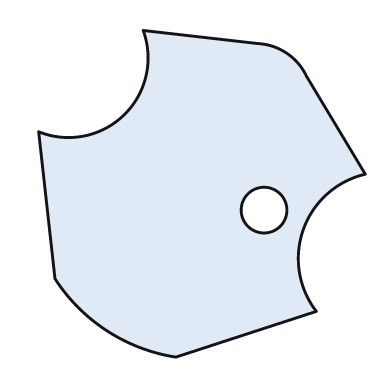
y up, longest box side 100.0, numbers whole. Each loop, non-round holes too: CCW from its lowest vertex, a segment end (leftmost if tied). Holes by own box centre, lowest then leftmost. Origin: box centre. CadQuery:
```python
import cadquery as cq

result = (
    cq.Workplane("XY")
    .moveTo(-8.0, -50.0)
    .lineTo(35.0, -36.0)
    .threePointArc((31.0, -11.0), (50.0, 6.0))
    .lineTo(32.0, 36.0)
    .threePointArc((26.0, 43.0), (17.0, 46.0))
    .lineTo(-18.0, 50.0)
    .threePointArc((-24.0, 24.0), (-50.0, 19.0))
    .lineTo(-45.0, -26.0)
    .threePointArc((-29.0, -42.0), (-8.0, -50.0))
    .close()
    .moveTo(19.0, -5.0)
    .circle(7.0)
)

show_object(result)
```